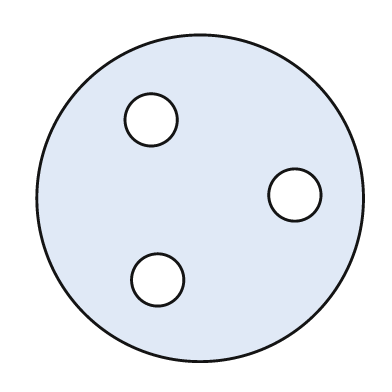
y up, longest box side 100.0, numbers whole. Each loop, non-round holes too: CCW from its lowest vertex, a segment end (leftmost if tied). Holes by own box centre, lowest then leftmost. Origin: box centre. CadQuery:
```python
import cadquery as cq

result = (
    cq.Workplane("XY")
    .moveTo(0.0, 0.0)
    .circle(50.0)
    .moveTo(-13.0, -25.0)
    .circle(8.0)
    .moveTo(29.0, 1.0)
    .circle(8.0)
    .moveTo(-15.0, 24.0)
    .circle(8.0)
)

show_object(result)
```